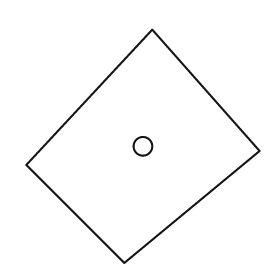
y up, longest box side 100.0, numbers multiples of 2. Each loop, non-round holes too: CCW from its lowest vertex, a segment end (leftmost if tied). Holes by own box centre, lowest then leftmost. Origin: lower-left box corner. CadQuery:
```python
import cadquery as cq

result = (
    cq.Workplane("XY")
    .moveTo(42.0, 0.0)
    .lineTo(100.0, 48.0)
    .lineTo(54.0, 100.0)
    .lineTo(0.0, 42.0)
    .close()
    .moveTo(50.0, 50.0)
    .circle(4.0)
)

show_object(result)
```